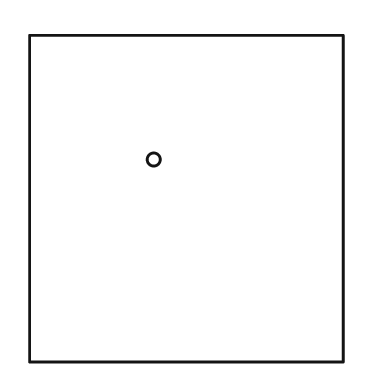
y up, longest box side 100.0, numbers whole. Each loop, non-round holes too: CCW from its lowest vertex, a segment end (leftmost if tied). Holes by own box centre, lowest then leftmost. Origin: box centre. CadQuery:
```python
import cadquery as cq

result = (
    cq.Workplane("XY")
    .moveTo(-48.0, -50.0)
    .lineTo(48.0, -50.0)
    .lineTo(48.0, 50.0)
    .lineTo(-48.0, 50.0)
    .close()
    .moveTo(-10.0, 12.0)
    .circle(2.0)
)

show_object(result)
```